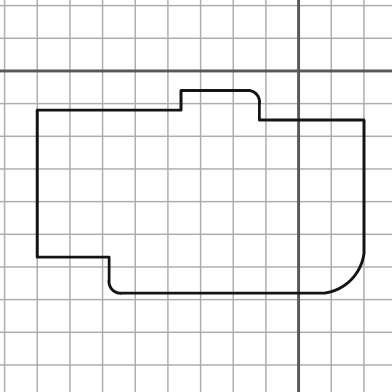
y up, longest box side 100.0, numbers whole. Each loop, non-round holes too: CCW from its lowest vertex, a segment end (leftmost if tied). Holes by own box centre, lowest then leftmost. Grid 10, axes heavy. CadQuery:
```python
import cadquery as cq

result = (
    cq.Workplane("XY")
    .moveTo(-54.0, -68.0)
    .lineTo(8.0, -68.0)
    .threePointArc((16.0, -64.0), (20.0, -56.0))
    .lineTo(20.0, -15.0)
    .lineTo(-12.0, -15.0)
    .lineTo(-12.0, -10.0)
    .threePointArc((-13.0, -7.0), (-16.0, -6.0))
    .lineTo(-36.0, -6.0)
    .lineTo(-36.0, -12.0)
    .lineTo(-80.0, -12.0)
    .lineTo(-80.0, -57.0)
    .lineTo(-58.0, -57.0)
    .lineTo(-58.0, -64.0)
    .threePointArc((-57.0, -67.0), (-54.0, -68.0))
    .close()
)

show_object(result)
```